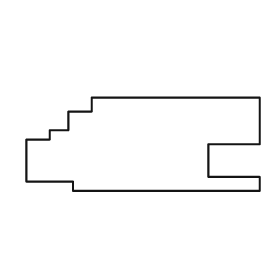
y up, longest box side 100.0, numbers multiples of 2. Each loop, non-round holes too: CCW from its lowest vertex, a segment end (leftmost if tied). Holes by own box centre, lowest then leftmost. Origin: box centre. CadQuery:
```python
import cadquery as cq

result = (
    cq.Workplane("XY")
    .moveTo(-30.0, -20.0)
    .lineTo(50.0, -20.0)
    .lineTo(50.0, -14.0)
    .lineTo(28.0, -14.0)
    .lineTo(28.0, 0.0)
    .lineTo(50.0, 0.0)
    .lineTo(50.0, 20.0)
    .lineTo(-22.0, 20.0)
    .lineTo(-22.0, 14.0)
    .lineTo(-32.0, 14.0)
    .lineTo(-32.0, 6.0)
    .lineTo(-40.0, 6.0)
    .lineTo(-40.0, 2.0)
    .lineTo(-50.0, 2.0)
    .lineTo(-50.0, -16.0)
    .lineTo(-30.0, -16.0)
    .close()
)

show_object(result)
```